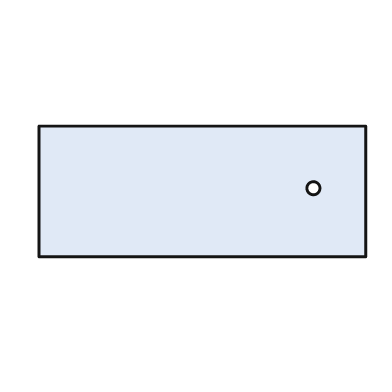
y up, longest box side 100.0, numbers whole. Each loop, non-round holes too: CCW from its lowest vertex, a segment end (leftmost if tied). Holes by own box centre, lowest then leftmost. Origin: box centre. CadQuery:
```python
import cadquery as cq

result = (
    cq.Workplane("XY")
    .moveTo(-50.0, -20.0)
    .lineTo(50.0, -20.0)
    .lineTo(50.0, 20.0)
    .lineTo(-50.0, 20.0)
    .close()
    .moveTo(34.0, 1.0)
    .circle(2.0)
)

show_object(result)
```